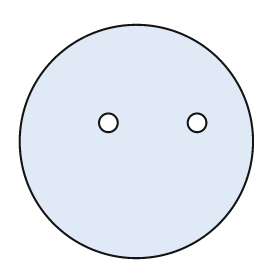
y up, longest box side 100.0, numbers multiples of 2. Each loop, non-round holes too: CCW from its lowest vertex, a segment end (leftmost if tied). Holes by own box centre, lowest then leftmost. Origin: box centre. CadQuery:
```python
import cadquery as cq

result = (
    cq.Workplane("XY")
    .moveTo(0.0, 0.0)
    .circle(50.0)
    .moveTo(-12.0, 8.0)
    .circle(4.0)
    .moveTo(26.0, 8.0)
    .circle(4.0)
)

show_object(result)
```